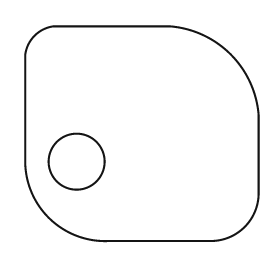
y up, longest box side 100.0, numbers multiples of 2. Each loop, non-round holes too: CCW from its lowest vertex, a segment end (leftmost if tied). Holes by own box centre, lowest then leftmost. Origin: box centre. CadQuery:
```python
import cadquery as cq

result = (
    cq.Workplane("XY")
    .moveTo(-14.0, -46.0)
    .lineTo(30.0, -46.0)
    .threePointArc((44.0, -40.0), (50.0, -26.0))
    .lineTo(50.0, 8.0)
    .threePointArc((38.0, 34.0), (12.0, 46.0))
    .lineTo(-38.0, 46.0)
    .threePointArc((-46.0, 42.0), (-50.0, 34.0))
    .lineTo(-50.0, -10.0)
    .threePointArc((-40.0, -36.0), (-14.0, -46.0))
    .close()
    .moveTo(-28.0, -12.0)
    .circle(12.0)
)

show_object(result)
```